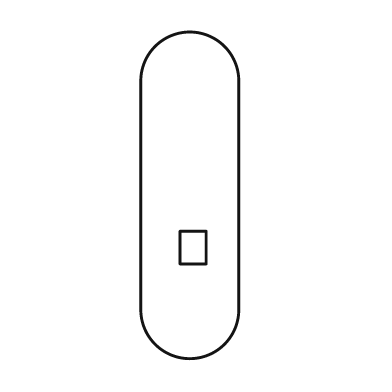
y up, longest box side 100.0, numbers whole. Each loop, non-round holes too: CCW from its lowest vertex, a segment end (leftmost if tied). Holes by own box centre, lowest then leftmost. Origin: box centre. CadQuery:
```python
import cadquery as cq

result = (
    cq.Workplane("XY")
    .moveTo(-15.0, -35.0)
    .threePointArc((0.0, -50.0), (15.0, -35.0))
    .lineTo(15.0, 35.0)
    .threePointArc((0.0, 50.0), (-15.0, 35.0))
    .close()
    .moveTo(-3.0, -21.0)
    .lineTo(5.0, -21.0)
    .lineTo(5.0, -11.0)
    .lineTo(-3.0, -11.0)
    .close()
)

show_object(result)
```